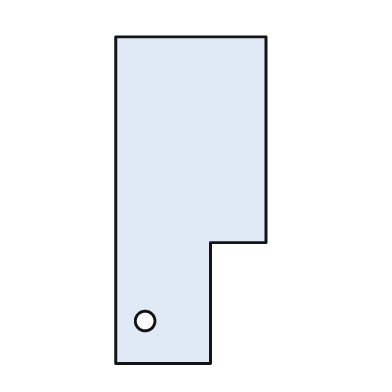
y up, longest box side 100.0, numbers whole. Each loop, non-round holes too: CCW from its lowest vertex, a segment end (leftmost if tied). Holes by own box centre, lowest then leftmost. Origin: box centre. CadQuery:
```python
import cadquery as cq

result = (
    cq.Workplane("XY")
    .moveTo(-23.0, -50.0)
    .lineTo(6.0, -50.0)
    .lineTo(6.0, -13.0)
    .lineTo(23.0, -13.0)
    .lineTo(23.0, 50.0)
    .lineTo(-23.0, 50.0)
    .close()
    .moveTo(-14.0, -37.0)
    .circle(3.0)
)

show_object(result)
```